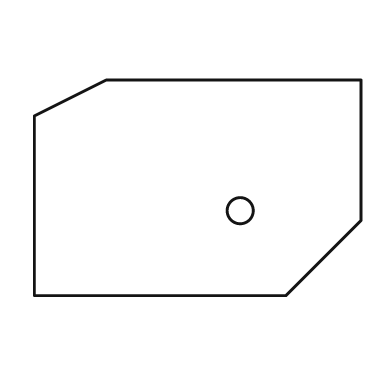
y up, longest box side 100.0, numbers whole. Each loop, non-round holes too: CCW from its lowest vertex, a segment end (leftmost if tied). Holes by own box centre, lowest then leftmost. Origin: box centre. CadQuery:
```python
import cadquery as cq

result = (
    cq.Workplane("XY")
    .moveTo(-50.0, -33.0)
    .lineTo(27.0, -33.0)
    .lineTo(50.0, -10.0)
    .lineTo(50.0, 33.0)
    .lineTo(-28.0, 33.0)
    .lineTo(-50.0, 22.0)
    .close()
    .moveTo(13.0, -7.0)
    .circle(4.0)
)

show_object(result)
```